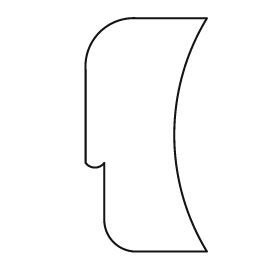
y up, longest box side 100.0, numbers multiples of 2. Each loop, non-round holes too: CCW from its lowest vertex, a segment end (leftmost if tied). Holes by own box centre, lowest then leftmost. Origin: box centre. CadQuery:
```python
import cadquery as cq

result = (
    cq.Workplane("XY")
    .moveTo(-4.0, -50.0)
    .lineTo(26.0, -50.0)
    .threePointArc((12.0, 0.0), (26.0, 50.0))
    .lineTo(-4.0, 50.0)
    .threePointArc((-20.0, 44.0), (-26.0, 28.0))
    .lineTo(-26.0, -12.0)
    .threePointArc((-22.0, -14.0), (-18.0, -12.0))
    .lineTo(-18.0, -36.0)
    .threePointArc((-14.0, -46.0), (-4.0, -50.0))
    .close()
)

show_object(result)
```